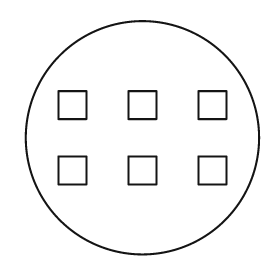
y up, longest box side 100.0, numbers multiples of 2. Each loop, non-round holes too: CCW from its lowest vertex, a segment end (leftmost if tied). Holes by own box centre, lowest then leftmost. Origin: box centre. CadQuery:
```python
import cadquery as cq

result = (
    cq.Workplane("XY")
    .moveTo(0.0, 0.0)
    .circle(50.0)
    .moveTo(-36.0, -20.0)
    .lineTo(-24.0, -20.0)
    .lineTo(-24.0, -8.0)
    .lineTo(-36.0, -8.0)
    .close()
    .moveTo(-6.0, -20.0)
    .lineTo(6.0, -20.0)
    .lineTo(6.0, -8.0)
    .lineTo(-6.0, -8.0)
    .close()
    .moveTo(24.0, -20.0)
    .lineTo(36.0, -20.0)
    .lineTo(36.0, -8.0)
    .lineTo(24.0, -8.0)
    .close()
    .moveTo(-36.0, 8.0)
    .lineTo(-24.0, 8.0)
    .lineTo(-24.0, 20.0)
    .lineTo(-36.0, 20.0)
    .close()
    .moveTo(-6.0, 8.0)
    .lineTo(6.0, 8.0)
    .lineTo(6.0, 20.0)
    .lineTo(-6.0, 20.0)
    .close()
    .moveTo(24.0, 8.0)
    .lineTo(36.0, 8.0)
    .lineTo(36.0, 20.0)
    .lineTo(24.0, 20.0)
    .close()
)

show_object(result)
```